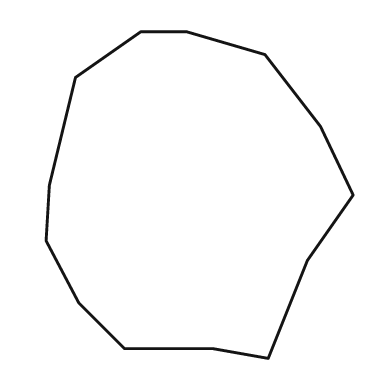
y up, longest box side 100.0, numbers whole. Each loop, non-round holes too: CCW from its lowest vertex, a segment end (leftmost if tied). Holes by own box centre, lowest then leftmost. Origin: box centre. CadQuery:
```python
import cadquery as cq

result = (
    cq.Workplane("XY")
    .moveTo(21.0, -50.0)
    .lineTo(33.0, -20.0)
    .lineTo(47.0, 0.0)
    .lineTo(37.0, 21.0)
    .lineTo(20.0, 43.0)
    .lineTo(-4.0, 50.0)
    .lineTo(-18.0, 50.0)
    .lineTo(-38.0, 36.0)
    .lineTo(-46.0, 3.0)
    .lineTo(-47.0, -14.0)
    .lineTo(-37.0, -33.0)
    .lineTo(-23.0, -47.0)
    .lineTo(4.0, -47.0)
    .close()
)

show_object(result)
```